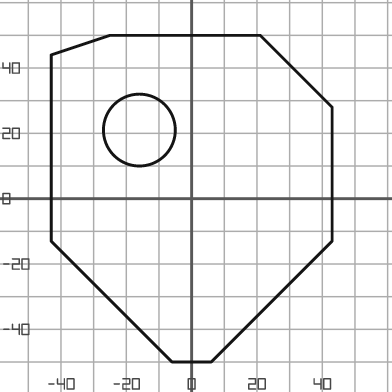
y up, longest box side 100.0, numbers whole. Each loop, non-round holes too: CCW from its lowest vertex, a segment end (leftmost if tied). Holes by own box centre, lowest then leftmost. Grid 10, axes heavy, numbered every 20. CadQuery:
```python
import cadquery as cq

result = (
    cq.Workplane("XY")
    .moveTo(-6.0, -50.0)
    .lineTo(6.0, -50.0)
    .lineTo(43.0, -13.0)
    .lineTo(43.0, 28.0)
    .lineTo(21.0, 50.0)
    .lineTo(-25.0, 50.0)
    .lineTo(-43.0, 44.0)
    .lineTo(-43.0, -13.0)
    .close()
    .moveTo(-16.0, 21.0)
    .circle(11.0)
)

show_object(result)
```